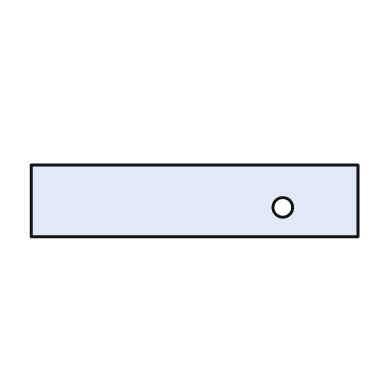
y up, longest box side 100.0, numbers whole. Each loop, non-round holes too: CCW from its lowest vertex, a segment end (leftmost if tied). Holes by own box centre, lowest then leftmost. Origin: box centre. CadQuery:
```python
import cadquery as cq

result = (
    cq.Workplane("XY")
    .moveTo(-50.0, -11.0)
    .lineTo(50.0, -11.0)
    .lineTo(50.0, 11.0)
    .lineTo(-50.0, 11.0)
    .close()
    .moveTo(27.0, -2.0)
    .circle(3.0)
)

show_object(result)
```